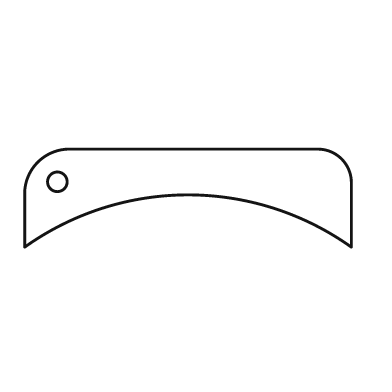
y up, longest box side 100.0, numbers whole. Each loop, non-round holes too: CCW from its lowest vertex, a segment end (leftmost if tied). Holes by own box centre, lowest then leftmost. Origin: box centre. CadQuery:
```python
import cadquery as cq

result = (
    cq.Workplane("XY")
    .moveTo(-50.0, -15.0)
    .threePointArc((0.0, 1.0), (50.0, -15.0))
    .lineTo(50.0, 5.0)
    .threePointArc((47.0, 12.0), (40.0, 15.0))
    .lineTo(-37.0, 15.0)
    .threePointArc((-46.0, 11.0), (-50.0, 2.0))
    .close()
    .moveTo(-40.0, 5.0)
    .circle(3.0)
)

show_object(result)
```